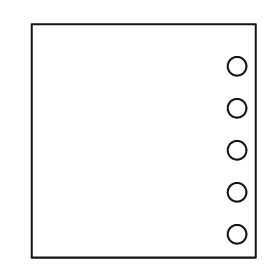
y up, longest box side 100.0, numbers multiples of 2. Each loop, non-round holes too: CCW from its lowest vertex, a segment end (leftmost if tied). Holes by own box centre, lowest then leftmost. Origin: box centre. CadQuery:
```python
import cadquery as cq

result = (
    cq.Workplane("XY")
    .moveTo(-48.0, -50.0)
    .lineTo(48.0, -50.0)
    .lineTo(48.0, 50.0)
    .lineTo(-48.0, 50.0)
    .close()
    .moveTo(40.0, -40.0)
    .circle(4.0)
    .moveTo(40.0, -22.0)
    .circle(4.0)
    .moveTo(40.0, -4.0)
    .circle(4.0)
    .moveTo(40.0, 14.0)
    .circle(4.0)
    .moveTo(40.0, 32.0)
    .circle(4.0)
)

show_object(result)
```